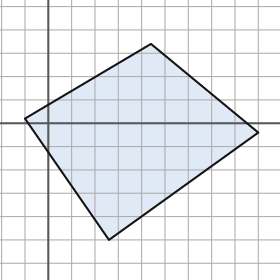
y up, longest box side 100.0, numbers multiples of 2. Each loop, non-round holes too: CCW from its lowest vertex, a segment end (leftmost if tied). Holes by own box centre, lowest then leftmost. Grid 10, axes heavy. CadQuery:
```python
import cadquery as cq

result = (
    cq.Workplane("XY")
    .moveTo(26.0, -50.0)
    .lineTo(90.0, -4.0)
    .lineTo(44.0, 34.0)
    .lineTo(-10.0, 2.0)
    .close()
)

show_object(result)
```